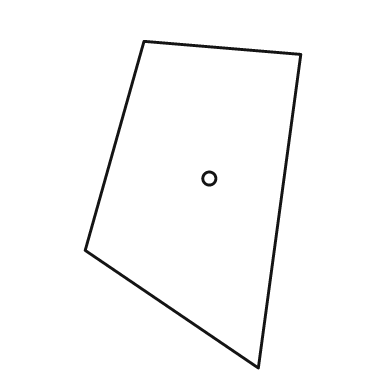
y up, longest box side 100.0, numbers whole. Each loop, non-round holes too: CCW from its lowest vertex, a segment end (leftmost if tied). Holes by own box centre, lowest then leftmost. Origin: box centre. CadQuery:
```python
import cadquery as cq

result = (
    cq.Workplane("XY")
    .moveTo(20.0, -50.0)
    .lineTo(33.0, 46.0)
    .lineTo(-15.0, 50.0)
    .lineTo(-33.0, -14.0)
    .close()
    .moveTo(5.0, 8.0)
    .circle(2.0)
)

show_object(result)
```